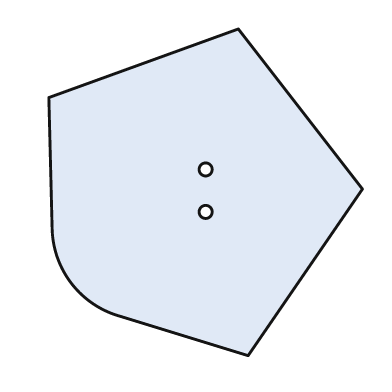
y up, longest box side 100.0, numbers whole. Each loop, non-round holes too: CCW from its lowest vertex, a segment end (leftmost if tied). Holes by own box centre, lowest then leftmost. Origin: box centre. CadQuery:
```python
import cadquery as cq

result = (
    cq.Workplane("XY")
    .moveTo(13.0, -50.0)
    .lineTo(48.0, 1.0)
    .lineTo(10.0, 50.0)
    .lineTo(-48.0, 29.0)
    .lineTo(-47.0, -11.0)
    .threePointArc((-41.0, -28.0), (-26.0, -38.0))
    .close()
    .moveTo(0.0, -6.0)
    .circle(2.0)
    .moveTo(0.0, 7.0)
    .circle(2.0)
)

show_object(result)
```